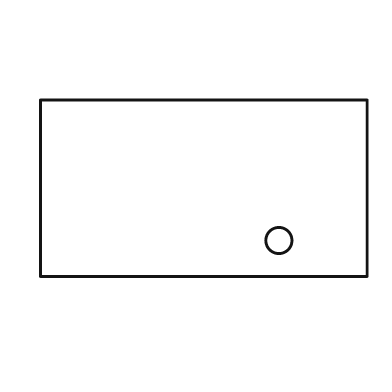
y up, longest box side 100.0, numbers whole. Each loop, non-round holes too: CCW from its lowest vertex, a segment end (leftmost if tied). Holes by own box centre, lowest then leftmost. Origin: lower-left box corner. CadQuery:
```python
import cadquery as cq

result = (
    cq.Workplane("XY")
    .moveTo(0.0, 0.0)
    .lineTo(100.0, 0.0)
    .lineTo(100.0, 54.0)
    .lineTo(0.0, 54.0)
    .close()
    .moveTo(73.0, 11.0)
    .circle(4.0)
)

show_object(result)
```